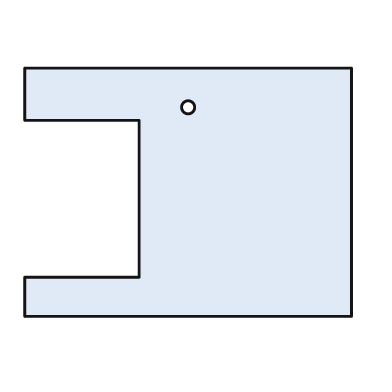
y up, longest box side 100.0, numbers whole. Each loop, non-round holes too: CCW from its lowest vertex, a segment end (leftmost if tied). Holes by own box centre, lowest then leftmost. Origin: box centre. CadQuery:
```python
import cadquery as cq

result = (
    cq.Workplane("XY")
    .moveTo(-50.0, -38.0)
    .lineTo(50.0, -38.0)
    .lineTo(50.0, 38.0)
    .lineTo(-50.0, 38.0)
    .lineTo(-50.0, 22.0)
    .lineTo(-15.0, 22.0)
    .lineTo(-15.0, -26.0)
    .lineTo(-50.0, -26.0)
    .close()
    .moveTo(0.0, 26.0)
    .circle(2.0)
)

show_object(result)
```